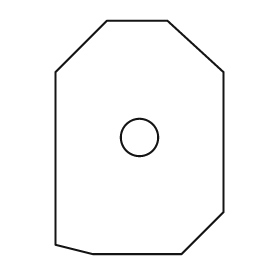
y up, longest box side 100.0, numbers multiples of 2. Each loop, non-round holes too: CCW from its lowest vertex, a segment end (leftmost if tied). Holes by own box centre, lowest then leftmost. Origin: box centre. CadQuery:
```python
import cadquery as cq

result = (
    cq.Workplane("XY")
    .moveTo(-20.0, -50.0)
    .lineTo(18.0, -50.0)
    .lineTo(36.0, -32.0)
    .lineTo(36.0, 28.0)
    .lineTo(12.0, 50.0)
    .lineTo(-14.0, 50.0)
    .lineTo(-36.0, 28.0)
    .lineTo(-36.0, -46.0)
    .close()
    .moveTo(0.0, 0.0)
    .circle(8.0)
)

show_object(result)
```